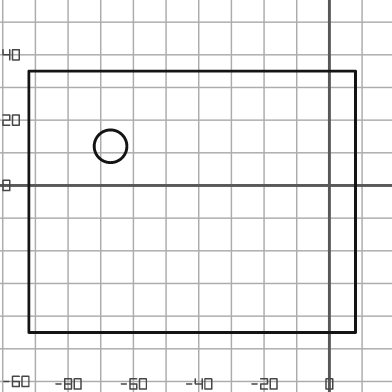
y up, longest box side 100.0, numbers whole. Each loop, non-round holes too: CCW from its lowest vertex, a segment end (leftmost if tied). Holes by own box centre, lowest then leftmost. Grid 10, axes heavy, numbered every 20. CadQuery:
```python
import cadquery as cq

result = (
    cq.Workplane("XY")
    .moveTo(-92.0, -45.0)
    .lineTo(8.0, -45.0)
    .lineTo(8.0, 35.0)
    .lineTo(-92.0, 35.0)
    .close()
    .moveTo(-67.0, 12.0)
    .circle(5.0)
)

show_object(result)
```